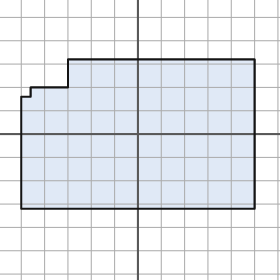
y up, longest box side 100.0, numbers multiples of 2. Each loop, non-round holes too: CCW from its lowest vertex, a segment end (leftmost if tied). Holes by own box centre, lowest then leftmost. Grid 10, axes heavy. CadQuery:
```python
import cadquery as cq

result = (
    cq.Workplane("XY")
    .moveTo(-50.0, -32.0)
    .lineTo(50.0, -32.0)
    .lineTo(50.0, 32.0)
    .lineTo(-30.0, 32.0)
    .lineTo(-30.0, 20.0)
    .lineTo(-46.0, 20.0)
    .lineTo(-46.0, 16.0)
    .lineTo(-50.0, 16.0)
    .close()
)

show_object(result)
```